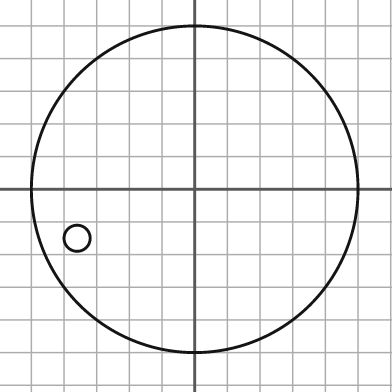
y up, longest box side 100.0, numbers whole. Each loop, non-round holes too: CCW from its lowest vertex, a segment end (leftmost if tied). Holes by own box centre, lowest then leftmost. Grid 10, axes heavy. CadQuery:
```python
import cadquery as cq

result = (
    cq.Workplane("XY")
    .moveTo(0.0, 0.0)
    .circle(50.0)
    .moveTo(-36.0, -15.0)
    .circle(4.0)
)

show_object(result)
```